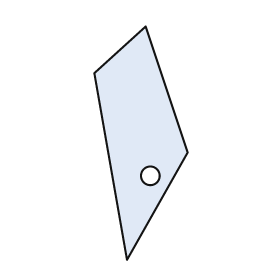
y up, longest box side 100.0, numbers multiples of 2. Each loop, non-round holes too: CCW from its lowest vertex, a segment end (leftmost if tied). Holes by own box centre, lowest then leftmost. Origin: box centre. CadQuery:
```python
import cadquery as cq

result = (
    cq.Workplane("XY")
    .moveTo(-6.0, -50.0)
    .lineTo(20.0, -4.0)
    .lineTo(2.0, 50.0)
    .lineTo(-20.0, 30.0)
    .close()
    .moveTo(4.0, -14.0)
    .circle(4.0)
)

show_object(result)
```